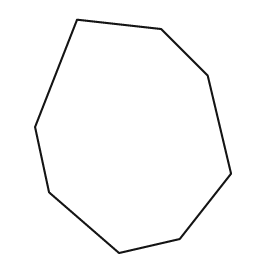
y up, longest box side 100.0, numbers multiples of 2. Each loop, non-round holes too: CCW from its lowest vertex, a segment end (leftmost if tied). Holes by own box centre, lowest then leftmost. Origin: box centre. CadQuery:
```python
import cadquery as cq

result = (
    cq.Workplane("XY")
    .moveTo(-6.0, -50.0)
    .lineTo(20.0, -44.0)
    .lineTo(42.0, -16.0)
    .lineTo(32.0, 26.0)
    .lineTo(12.0, 46.0)
    .lineTo(-24.0, 50.0)
    .lineTo(-42.0, 4.0)
    .lineTo(-36.0, -24.0)
    .close()
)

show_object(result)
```